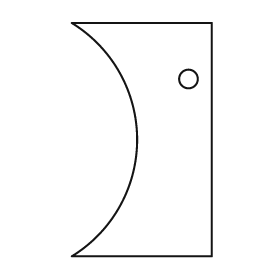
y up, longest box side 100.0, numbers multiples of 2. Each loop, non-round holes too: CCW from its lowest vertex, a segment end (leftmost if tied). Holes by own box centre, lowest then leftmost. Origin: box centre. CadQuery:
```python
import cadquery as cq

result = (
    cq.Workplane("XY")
    .moveTo(-30.0, -50.0)
    .lineTo(30.0, -50.0)
    .lineTo(30.0, 50.0)
    .lineTo(-30.0, 50.0)
    .threePointArc((-2.0, 0.0), (-30.0, -50.0))
    .close()
    .moveTo(20.0, 26.0)
    .circle(4.0)
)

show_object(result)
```